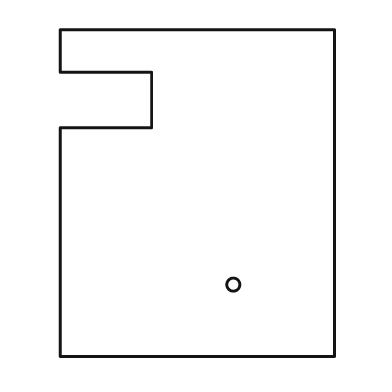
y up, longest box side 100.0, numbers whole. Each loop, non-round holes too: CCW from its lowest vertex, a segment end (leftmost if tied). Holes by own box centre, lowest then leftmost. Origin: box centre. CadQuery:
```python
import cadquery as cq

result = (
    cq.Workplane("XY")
    .moveTo(-42.0, -50.0)
    .lineTo(42.0, -50.0)
    .lineTo(42.0, 50.0)
    .lineTo(-42.0, 50.0)
    .lineTo(-42.0, 37.0)
    .lineTo(-14.0, 37.0)
    .lineTo(-14.0, 20.0)
    .lineTo(-42.0, 20.0)
    .close()
    .moveTo(11.0, -28.0)
    .circle(2.0)
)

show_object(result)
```